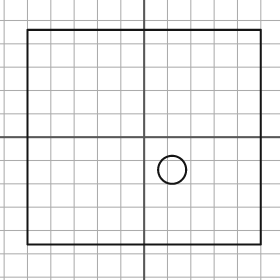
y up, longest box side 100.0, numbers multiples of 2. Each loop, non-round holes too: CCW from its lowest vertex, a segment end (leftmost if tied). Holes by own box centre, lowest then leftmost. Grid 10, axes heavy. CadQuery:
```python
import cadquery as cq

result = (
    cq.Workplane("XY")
    .moveTo(-50.0, -46.0)
    .lineTo(50.0, -46.0)
    .lineTo(50.0, 46.0)
    .lineTo(-50.0, 46.0)
    .close()
    .moveTo(12.0, -14.0)
    .circle(6.0)
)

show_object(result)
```